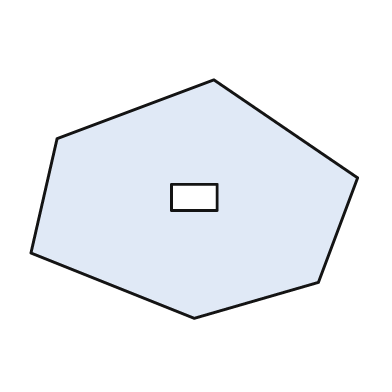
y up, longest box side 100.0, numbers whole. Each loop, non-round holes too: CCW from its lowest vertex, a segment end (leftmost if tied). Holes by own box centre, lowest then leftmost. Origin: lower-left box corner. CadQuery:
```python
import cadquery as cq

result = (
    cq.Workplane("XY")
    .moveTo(50.0, 0.0)
    .lineTo(88.0, 11.0)
    .lineTo(100.0, 43.0)
    .lineTo(56.0, 73.0)
    .lineTo(8.0, 55.0)
    .lineTo(0.0, 20.0)
    .close()
    .moveTo(43.0, 33.0)
    .lineTo(57.0, 33.0)
    .lineTo(57.0, 41.0)
    .lineTo(43.0, 41.0)
    .close()
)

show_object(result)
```